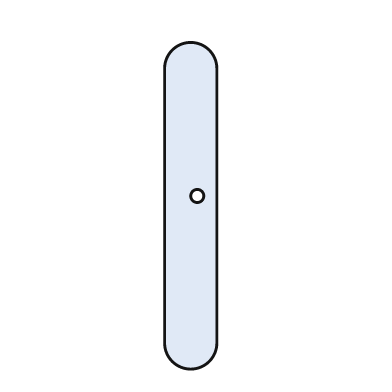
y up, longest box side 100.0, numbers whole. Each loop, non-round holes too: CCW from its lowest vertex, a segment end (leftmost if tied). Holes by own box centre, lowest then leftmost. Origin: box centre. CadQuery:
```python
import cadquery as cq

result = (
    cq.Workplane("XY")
    .moveTo(-8.0, -42.0)
    .threePointArc((0.0, -50.0), (8.0, -42.0))
    .lineTo(8.0, 42.0)
    .threePointArc((0.0, 50.0), (-8.0, 42.0))
    .close()
    .moveTo(2.0, 3.0)
    .circle(2.0)
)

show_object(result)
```